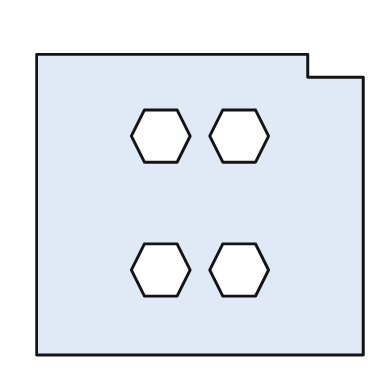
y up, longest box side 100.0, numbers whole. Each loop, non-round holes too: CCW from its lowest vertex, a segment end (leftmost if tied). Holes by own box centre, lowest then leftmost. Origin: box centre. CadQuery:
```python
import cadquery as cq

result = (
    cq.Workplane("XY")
    .moveTo(-50.0, -46.0)
    .lineTo(50.0, -46.0)
    .lineTo(50.0, 39.0)
    .lineTo(33.0, 39.0)
    .lineTo(33.0, 46.0)
    .lineTo(-50.0, 46.0)
    .close()
    .moveTo(-17.0, -28.0)
    .lineTo(-7.0, -28.0)
    .lineTo(-3.0, -20.0)
    .lineTo(-7.0, -12.0)
    .lineTo(-17.0, -12.0)
    .lineTo(-21.0, -20.0)
    .close()
    .moveTo(7.0, -28.0)
    .lineTo(17.0, -28.0)
    .lineTo(21.0, -20.0)
    .lineTo(17.0, -12.0)
    .lineTo(7.0, -12.0)
    .lineTo(3.0, -20.0)
    .close()
    .moveTo(-17.0, 13.0)
    .lineTo(-7.0, 13.0)
    .lineTo(-3.0, 21.0)
    .lineTo(-7.0, 29.0)
    .lineTo(-17.0, 29.0)
    .lineTo(-21.0, 21.0)
    .close()
    .moveTo(7.0, 13.0)
    .lineTo(17.0, 13.0)
    .lineTo(21.0, 21.0)
    .lineTo(17.0, 29.0)
    .lineTo(7.0, 29.0)
    .lineTo(3.0, 21.0)
    .close()
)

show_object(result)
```